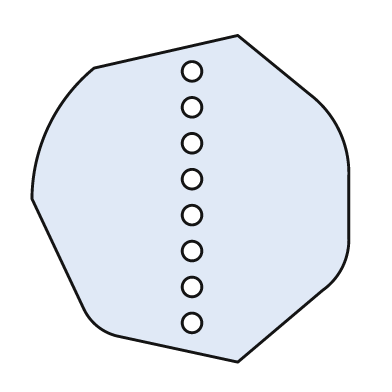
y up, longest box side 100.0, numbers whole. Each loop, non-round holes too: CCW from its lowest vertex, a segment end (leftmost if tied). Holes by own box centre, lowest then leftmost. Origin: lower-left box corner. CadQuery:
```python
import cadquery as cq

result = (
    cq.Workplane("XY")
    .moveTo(63.0, 0.0)
    .lineTo(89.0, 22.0)
    .threePointArc((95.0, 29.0), (97.0, 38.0))
    .lineTo(97.0, 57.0)
    .threePointArc((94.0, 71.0), (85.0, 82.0))
    .lineTo(63.0, 100.0)
    .lineTo(19.0, 90.0)
    .threePointArc((5.0, 72.0), (0.0, 50.0))
    .lineTo(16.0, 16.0)
    .threePointArc((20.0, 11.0), (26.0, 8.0))
    .close()
    .moveTo(49.0, 12.0)
    .circle(3.0)
    .moveTo(49.0, 23.0)
    .circle(3.0)
    .moveTo(49.0, 34.0)
    .circle(3.0)
    .moveTo(49.0, 45.0)
    .circle(3.0)
    .moveTo(49.0, 56.0)
    .circle(3.0)
    .moveTo(49.0, 67.0)
    .circle(3.0)
    .moveTo(49.0, 78.0)
    .circle(3.0)
    .moveTo(49.0, 89.0)
    .circle(3.0)
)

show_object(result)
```